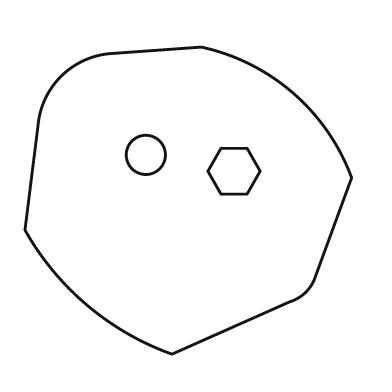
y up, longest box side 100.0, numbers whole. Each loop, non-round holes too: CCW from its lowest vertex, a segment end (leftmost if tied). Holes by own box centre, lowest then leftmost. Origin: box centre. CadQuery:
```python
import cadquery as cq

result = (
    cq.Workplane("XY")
    .moveTo(-5.0, -47.0)
    .lineTo(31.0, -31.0)
    .threePointArc((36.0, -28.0), (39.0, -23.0))
    .lineTo(50.0, 7.0)
    .threePointArc((32.0, 33.0), (4.0, 47.0))
    .lineTo(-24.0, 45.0)
    .threePointArc((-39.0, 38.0), (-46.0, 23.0))
    .lineTo(-50.0, -9.0)
    .threePointArc((-31.0, -32.0), (-5.0, -47.0))
    .close()
    .moveTo(10.0, 2.0)
    .lineTo(18.0, 2.0)
    .lineTo(22.0, 9.0)
    .lineTo(18.0, 16.0)
    .lineTo(10.0, 16.0)
    .lineTo(6.0, 9.0)
    .close()
    .moveTo(-13.0, 14.0)
    .circle(6.0)
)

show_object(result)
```